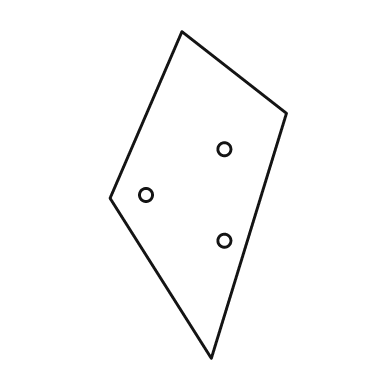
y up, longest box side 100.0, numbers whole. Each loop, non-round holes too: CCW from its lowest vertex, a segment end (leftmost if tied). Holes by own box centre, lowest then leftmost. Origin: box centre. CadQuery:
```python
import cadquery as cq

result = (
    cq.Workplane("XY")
    .moveTo(4.0, -50.0)
    .lineTo(27.0, 25.0)
    .lineTo(-5.0, 50.0)
    .lineTo(-27.0, -1.0)
    .close()
    .moveTo(8.0, -14.0)
    .circle(2.0)
    .moveTo(-16.0, 0.0)
    .circle(2.0)
    .moveTo(8.0, 14.0)
    .circle(2.0)
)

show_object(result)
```